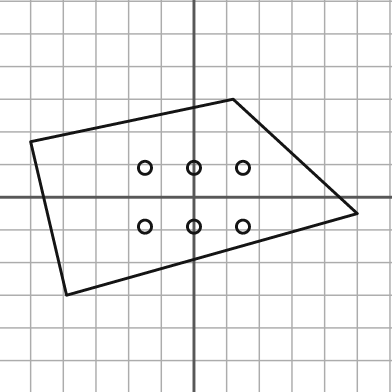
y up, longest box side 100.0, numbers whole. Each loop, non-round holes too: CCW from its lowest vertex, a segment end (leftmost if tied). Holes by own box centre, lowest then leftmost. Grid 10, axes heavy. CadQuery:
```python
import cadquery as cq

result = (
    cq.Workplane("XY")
    .moveTo(-39.0, -30.0)
    .lineTo(50.0, -5.0)
    .lineTo(12.0, 30.0)
    .lineTo(-50.0, 17.0)
    .close()
    .moveTo(-15.0, -9.0)
    .circle(2.0)
    .moveTo(0.0, -9.0)
    .circle(2.0)
    .moveTo(15.0, -9.0)
    .circle(2.0)
    .moveTo(-15.0, 9.0)
    .circle(2.0)
    .moveTo(0.0, 9.0)
    .circle(2.0)
    .moveTo(15.0, 9.0)
    .circle(2.0)
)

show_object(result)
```